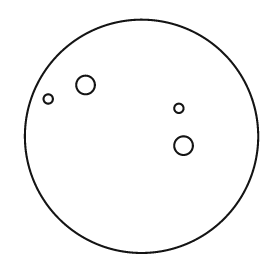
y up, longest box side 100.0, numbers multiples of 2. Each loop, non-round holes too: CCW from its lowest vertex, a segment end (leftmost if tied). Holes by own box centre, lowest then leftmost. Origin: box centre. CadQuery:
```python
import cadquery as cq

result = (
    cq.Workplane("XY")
    .moveTo(0.0, 0.0)
    .circle(50.0)
    .moveTo(18.0, -4.0)
    .circle(4.0)
    .moveTo(16.0, 12.0)
    .circle(2.0)
    .moveTo(-40.0, 16.0)
    .circle(2.0)
    .moveTo(-24.0, 22.0)
    .circle(4.0)
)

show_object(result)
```